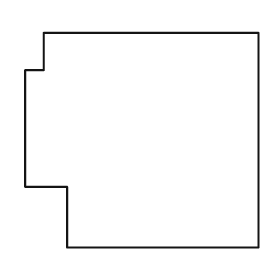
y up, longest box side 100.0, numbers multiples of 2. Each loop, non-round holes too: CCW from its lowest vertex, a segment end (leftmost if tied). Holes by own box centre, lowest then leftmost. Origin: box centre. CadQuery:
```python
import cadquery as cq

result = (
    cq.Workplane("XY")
    .moveTo(-32.0, -46.0)
    .lineTo(50.0, -46.0)
    .lineTo(50.0, 46.0)
    .lineTo(-42.0, 46.0)
    .lineTo(-42.0, 30.0)
    .lineTo(-50.0, 30.0)
    .lineTo(-50.0, -20.0)
    .lineTo(-32.0, -20.0)
    .close()
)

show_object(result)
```